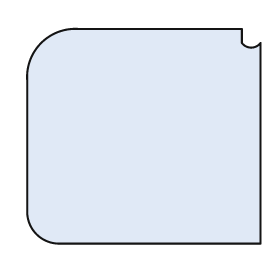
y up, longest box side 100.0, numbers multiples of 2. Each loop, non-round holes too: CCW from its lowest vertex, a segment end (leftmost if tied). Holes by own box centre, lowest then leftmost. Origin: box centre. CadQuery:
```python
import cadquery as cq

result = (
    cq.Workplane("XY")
    .moveTo(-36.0, -46.0)
    .lineTo(50.0, -46.0)
    .lineTo(50.0, 40.0)
    .threePointArc((46.0, 38.0), (42.0, 40.0))
    .lineTo(42.0, 46.0)
    .lineTo(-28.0, 46.0)
    .threePointArc((-44.0, 40.0), (-50.0, 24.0))
    .lineTo(-50.0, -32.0)
    .threePointArc((-46.0, -42.0), (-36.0, -46.0))
    .close()
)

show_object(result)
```